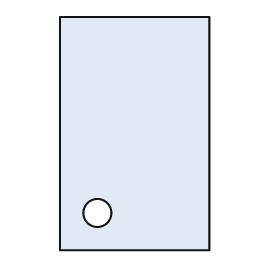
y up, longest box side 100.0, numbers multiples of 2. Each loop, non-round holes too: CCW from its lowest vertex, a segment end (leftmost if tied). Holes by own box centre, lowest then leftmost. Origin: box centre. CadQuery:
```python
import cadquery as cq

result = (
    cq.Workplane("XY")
    .moveTo(-32.0, -50.0)
    .lineTo(32.0, -50.0)
    .lineTo(32.0, 50.0)
    .lineTo(-32.0, 50.0)
    .close()
    .moveTo(-16.0, -34.0)
    .circle(6.0)
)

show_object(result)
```